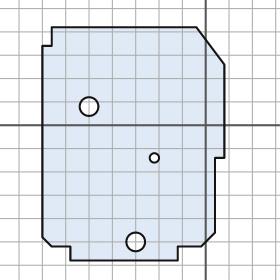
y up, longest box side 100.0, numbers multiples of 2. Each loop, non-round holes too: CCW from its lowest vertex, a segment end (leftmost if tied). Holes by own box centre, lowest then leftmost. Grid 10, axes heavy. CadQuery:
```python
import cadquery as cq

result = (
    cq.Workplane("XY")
    .moveTo(-58.0, -58.0)
    .lineTo(-12.0, -58.0)
    .lineTo(-12.0, -52.0)
    .lineTo(-2.0, -52.0)
    .lineTo(4.0, -46.0)
    .lineTo(4.0, -14.0)
    .lineTo(8.0, -14.0)
    .lineTo(8.0, 26.0)
    .lineTo(-4.0, 42.0)
    .lineTo(-66.0, 42.0)
    .lineTo(-66.0, 34.0)
    .lineTo(-70.0, 34.0)
    .lineTo(-70.0, -48.0)
    .lineTo(-66.0, -52.0)
    .lineTo(-58.0, -52.0)
    .close()
    .moveTo(-30.0, -50.0)
    .circle(4.0)
    .moveTo(-22.0, -14.0)
    .circle(2.0)
    .moveTo(-50.0, 8.0)
    .circle(4.0)
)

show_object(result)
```